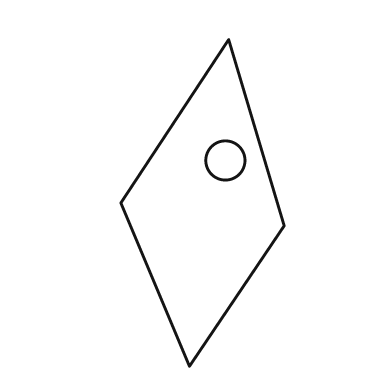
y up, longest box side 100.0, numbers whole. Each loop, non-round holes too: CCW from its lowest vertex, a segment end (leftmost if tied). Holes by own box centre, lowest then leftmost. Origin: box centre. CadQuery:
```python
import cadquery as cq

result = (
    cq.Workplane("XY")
    .moveTo(-4.0, -50.0)
    .lineTo(25.0, -7.0)
    .lineTo(8.0, 50.0)
    .lineTo(-25.0, 0.0)
    .close()
    .moveTo(7.0, 13.0)
    .circle(6.0)
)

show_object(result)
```